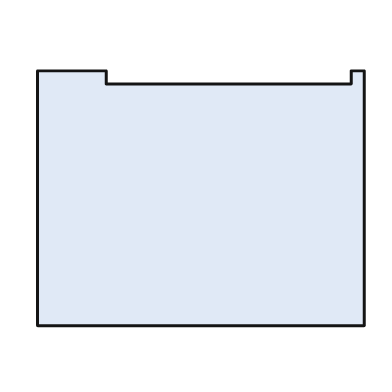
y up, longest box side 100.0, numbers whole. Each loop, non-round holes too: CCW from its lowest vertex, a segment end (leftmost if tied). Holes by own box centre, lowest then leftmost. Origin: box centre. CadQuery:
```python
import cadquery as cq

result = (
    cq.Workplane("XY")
    .moveTo(-50.0, -39.0)
    .lineTo(50.0, -39.0)
    .lineTo(50.0, 39.0)
    .lineTo(46.0, 39.0)
    .lineTo(46.0, 35.0)
    .lineTo(-29.0, 35.0)
    .lineTo(-29.0, 39.0)
    .lineTo(-50.0, 39.0)
    .close()
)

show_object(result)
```